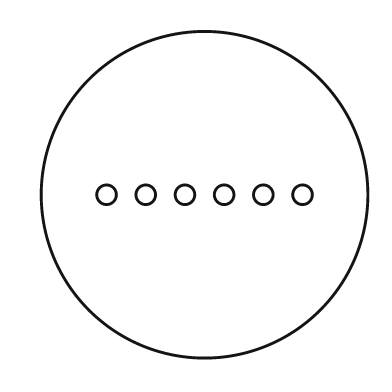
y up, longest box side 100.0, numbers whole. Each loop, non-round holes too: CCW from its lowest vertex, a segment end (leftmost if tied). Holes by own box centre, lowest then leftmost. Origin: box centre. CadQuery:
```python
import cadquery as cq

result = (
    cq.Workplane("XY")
    .moveTo(0.0, 0.0)
    .circle(50.0)
    .moveTo(-30.0, 0.0)
    .circle(3.0)
    .moveTo(-18.0, 0.0)
    .circle(3.0)
    .moveTo(-6.0, 0.0)
    .circle(3.0)
    .moveTo(6.0, 0.0)
    .circle(3.0)
    .moveTo(18.0, 0.0)
    .circle(3.0)
    .moveTo(30.0, 0.0)
    .circle(3.0)
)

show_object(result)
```